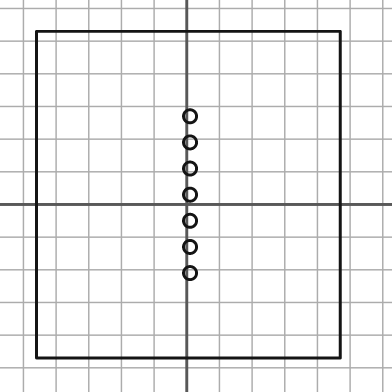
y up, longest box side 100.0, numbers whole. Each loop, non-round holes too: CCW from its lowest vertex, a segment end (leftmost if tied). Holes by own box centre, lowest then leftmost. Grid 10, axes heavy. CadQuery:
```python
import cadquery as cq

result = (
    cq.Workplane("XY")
    .moveTo(-46.0, -47.0)
    .lineTo(47.0, -47.0)
    .lineTo(47.0, 53.0)
    .lineTo(-46.0, 53.0)
    .close()
    .moveTo(1.0, -21.0)
    .circle(2.0)
    .moveTo(1.0, -13.0)
    .circle(2.0)
    .moveTo(1.0, -5.0)
    .circle(2.0)
    .moveTo(1.0, 3.0)
    .circle(2.0)
    .moveTo(1.0, 11.0)
    .circle(2.0)
    .moveTo(1.0, 19.0)
    .circle(2.0)
    .moveTo(1.0, 27.0)
    .circle(2.0)
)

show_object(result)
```